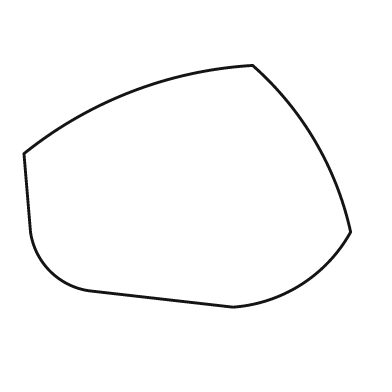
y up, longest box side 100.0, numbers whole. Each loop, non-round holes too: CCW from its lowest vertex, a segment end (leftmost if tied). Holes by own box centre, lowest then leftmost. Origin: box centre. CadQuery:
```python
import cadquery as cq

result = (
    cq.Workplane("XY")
    .moveTo(14.0, -37.0)
    .threePointArc((35.0, -30.0), (50.0, -14.0))
    .threePointArc((39.0, 14.0), (20.0, 37.0))
    .threePointArc((-17.0, 29.0), (-50.0, 10.0))
    .lineTo(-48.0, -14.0)
    .threePointArc((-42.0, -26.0), (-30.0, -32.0))
    .close()
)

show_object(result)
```